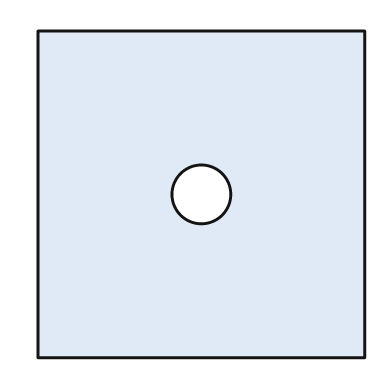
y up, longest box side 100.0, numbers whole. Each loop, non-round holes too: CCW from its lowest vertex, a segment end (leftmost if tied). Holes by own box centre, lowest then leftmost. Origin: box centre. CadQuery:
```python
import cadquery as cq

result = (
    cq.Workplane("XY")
    .moveTo(-50.0, -50.0)
    .lineTo(50.0, -50.0)
    .lineTo(50.0, 50.0)
    .lineTo(-50.0, 50.0)
    .close()
    .moveTo(0.0, 0.0)
    .circle(9.0)
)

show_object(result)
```